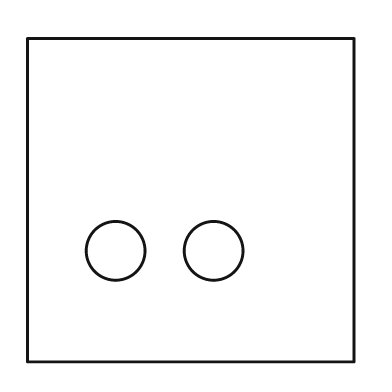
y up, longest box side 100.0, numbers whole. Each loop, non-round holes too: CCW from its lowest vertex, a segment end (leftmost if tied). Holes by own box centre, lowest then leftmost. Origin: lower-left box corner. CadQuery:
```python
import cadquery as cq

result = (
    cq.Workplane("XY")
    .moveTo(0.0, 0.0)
    .lineTo(100.0, 0.0)
    .lineTo(100.0, 99.0)
    .lineTo(0.0, 99.0)
    .close()
    .moveTo(27.0, 34.0)
    .circle(9.0)
    .moveTo(57.0, 34.0)
    .circle(9.0)
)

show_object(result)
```